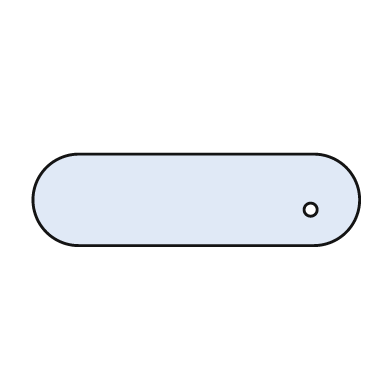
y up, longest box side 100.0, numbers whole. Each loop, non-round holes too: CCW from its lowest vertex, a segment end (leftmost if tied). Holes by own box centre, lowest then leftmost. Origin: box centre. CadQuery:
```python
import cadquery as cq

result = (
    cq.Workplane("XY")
    .moveTo(-36.0, -14.0)
    .lineTo(36.0, -14.0)
    .threePointArc((50.0, 0.0), (36.0, 14.0))
    .lineTo(-36.0, 14.0)
    .threePointArc((-50.0, 0.0), (-36.0, -14.0))
    .close()
    .moveTo(35.0, -3.0)
    .circle(2.0)
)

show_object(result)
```